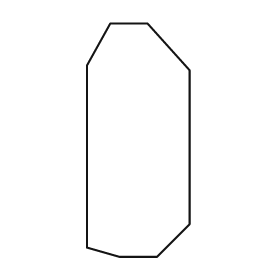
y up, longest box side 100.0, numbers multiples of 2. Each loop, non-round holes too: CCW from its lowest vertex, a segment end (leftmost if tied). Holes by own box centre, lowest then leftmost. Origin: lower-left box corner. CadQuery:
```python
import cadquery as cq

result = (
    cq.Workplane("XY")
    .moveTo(14.0, 0.0)
    .lineTo(30.0, 0.0)
    .lineTo(44.0, 14.0)
    .lineTo(44.0, 80.0)
    .lineTo(26.0, 100.0)
    .lineTo(10.0, 100.0)
    .lineTo(0.0, 82.0)
    .lineTo(0.0, 4.0)
    .close()
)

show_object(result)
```